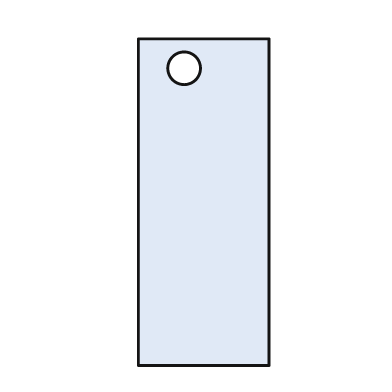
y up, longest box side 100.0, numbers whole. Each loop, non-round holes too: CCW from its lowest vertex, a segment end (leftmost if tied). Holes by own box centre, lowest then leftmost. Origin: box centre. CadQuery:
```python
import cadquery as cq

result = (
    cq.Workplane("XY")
    .moveTo(-20.0, -50.0)
    .lineTo(20.0, -50.0)
    .lineTo(20.0, 50.0)
    .lineTo(-20.0, 50.0)
    .close()
    .moveTo(-6.0, 41.0)
    .circle(5.0)
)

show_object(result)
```